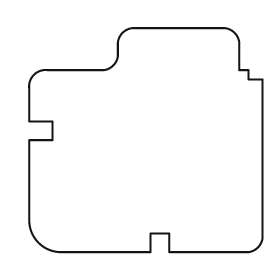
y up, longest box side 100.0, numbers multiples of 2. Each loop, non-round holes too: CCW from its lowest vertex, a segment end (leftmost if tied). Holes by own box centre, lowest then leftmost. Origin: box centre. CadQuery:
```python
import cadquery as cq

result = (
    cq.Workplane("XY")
    .moveTo(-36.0, -48.0)
    .lineTo(2.0, -48.0)
    .lineTo(2.0, -40.0)
    .lineTo(10.0, -40.0)
    .lineTo(10.0, -48.0)
    .lineTo(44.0, -48.0)
    .threePointArc((48.0, -46.0), (50.0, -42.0))
    .lineTo(50.0, 26.0)
    .lineTo(44.0, 26.0)
    .lineTo(44.0, 30.0)
    .lineTo(40.0, 30.0)
    .lineTo(40.0, 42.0)
    .threePointArc((38.0, 46.0), (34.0, 48.0))
    .lineTo(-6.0, 48.0)
    .threePointArc((-10.0, 46.0), (-12.0, 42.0))
    .lineTo(-12.0, 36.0)
    .threePointArc((-14.0, 32.0), (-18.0, 30.0))
    .lineTo(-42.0, 30.0)
    .threePointArc((-48.0, 28.0), (-50.0, 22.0))
    .lineTo(-50.0, 8.0)
    .lineTo(-40.0, 8.0)
    .lineTo(-40.0, 0.0)
    .lineTo(-50.0, 0.0)
    .lineTo(-50.0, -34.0)
    .threePointArc((-46.0, -44.0), (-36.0, -48.0))
    .close()
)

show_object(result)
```